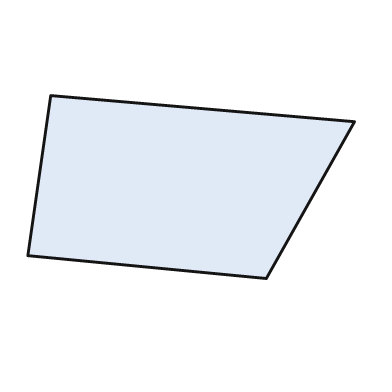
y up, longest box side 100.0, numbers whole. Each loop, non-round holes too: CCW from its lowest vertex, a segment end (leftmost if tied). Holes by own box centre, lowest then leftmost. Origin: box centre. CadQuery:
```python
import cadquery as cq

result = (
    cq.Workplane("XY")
    .moveTo(23.0, -28.0)
    .lineTo(50.0, 20.0)
    .lineTo(-43.0, 28.0)
    .lineTo(-50.0, -21.0)
    .close()
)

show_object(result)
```